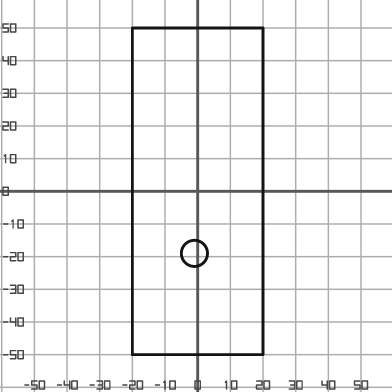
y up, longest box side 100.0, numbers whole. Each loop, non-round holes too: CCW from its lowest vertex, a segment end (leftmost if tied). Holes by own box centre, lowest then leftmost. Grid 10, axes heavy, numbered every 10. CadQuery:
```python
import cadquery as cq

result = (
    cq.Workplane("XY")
    .moveTo(-20.0, -50.0)
    .lineTo(20.0, -50.0)
    .lineTo(20.0, 50.0)
    .lineTo(-20.0, 50.0)
    .close()
    .moveTo(-1.0, -19.0)
    .circle(4.0)
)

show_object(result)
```